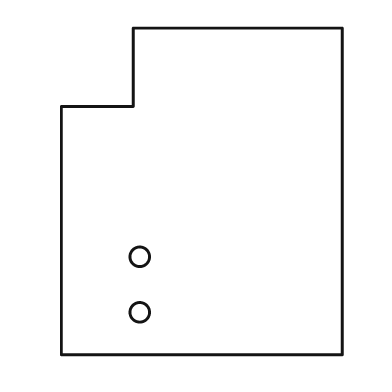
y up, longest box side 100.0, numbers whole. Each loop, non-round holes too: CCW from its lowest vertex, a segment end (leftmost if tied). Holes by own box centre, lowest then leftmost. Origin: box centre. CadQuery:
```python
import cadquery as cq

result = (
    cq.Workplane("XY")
    .moveTo(-43.0, -50.0)
    .lineTo(43.0, -50.0)
    .lineTo(43.0, 50.0)
    .lineTo(-21.0, 50.0)
    .lineTo(-21.0, 26.0)
    .lineTo(-43.0, 26.0)
    .close()
    .moveTo(-19.0, -37.0)
    .circle(3.0)
    .moveTo(-19.0, -20.0)
    .circle(3.0)
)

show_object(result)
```